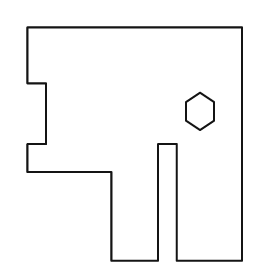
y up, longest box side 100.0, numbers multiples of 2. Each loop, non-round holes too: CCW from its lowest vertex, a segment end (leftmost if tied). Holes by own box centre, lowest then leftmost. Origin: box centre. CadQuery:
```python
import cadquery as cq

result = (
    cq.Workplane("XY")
    .moveTo(-10.0, -50.0)
    .lineTo(10.0, -50.0)
    .lineTo(10.0, 0.0)
    .lineTo(18.0, 0.0)
    .lineTo(18.0, -50.0)
    .lineTo(46.0, -50.0)
    .lineTo(46.0, 50.0)
    .lineTo(-46.0, 50.0)
    .lineTo(-46.0, 26.0)
    .lineTo(-38.0, 26.0)
    .lineTo(-38.0, 0.0)
    .lineTo(-46.0, 0.0)
    .lineTo(-46.0, -12.0)
    .lineTo(-10.0, -12.0)
    .close()
    .moveTo(28.0, 6.0)
    .lineTo(34.0, 10.0)
    .lineTo(34.0, 18.0)
    .lineTo(28.0, 22.0)
    .lineTo(22.0, 18.0)
    .lineTo(22.0, 10.0)
    .close()
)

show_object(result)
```